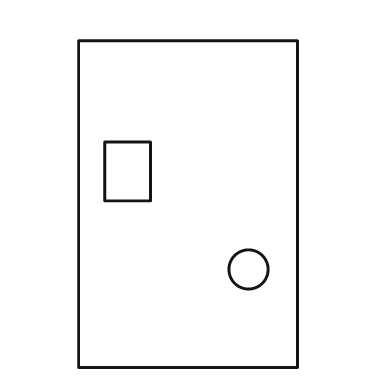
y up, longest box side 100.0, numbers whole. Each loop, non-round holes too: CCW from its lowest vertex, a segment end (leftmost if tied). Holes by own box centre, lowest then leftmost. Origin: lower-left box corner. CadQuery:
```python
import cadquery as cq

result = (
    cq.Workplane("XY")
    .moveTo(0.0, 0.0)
    .lineTo(67.0, 0.0)
    .lineTo(67.0, 100.0)
    .lineTo(0.0, 100.0)
    .close()
    .moveTo(52.0, 30.0)
    .circle(6.0)
    .moveTo(8.0, 51.0)
    .lineTo(22.0, 51.0)
    .lineTo(22.0, 69.0)
    .lineTo(8.0, 69.0)
    .close()
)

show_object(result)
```